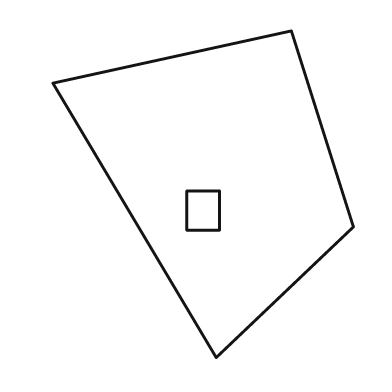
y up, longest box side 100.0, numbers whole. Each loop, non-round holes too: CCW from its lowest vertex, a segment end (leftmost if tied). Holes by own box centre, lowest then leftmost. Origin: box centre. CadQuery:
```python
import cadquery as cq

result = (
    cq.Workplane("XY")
    .moveTo(4.0, -50.0)
    .lineTo(46.0, -10.0)
    .lineTo(27.0, 50.0)
    .lineTo(-46.0, 34.0)
    .close()
    .moveTo(-5.0, -11.0)
    .lineTo(5.0, -11.0)
    .lineTo(5.0, 1.0)
    .lineTo(-5.0, 1.0)
    .close()
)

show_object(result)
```